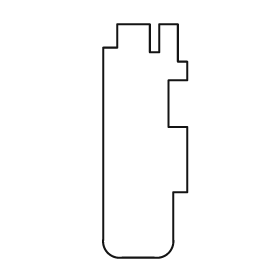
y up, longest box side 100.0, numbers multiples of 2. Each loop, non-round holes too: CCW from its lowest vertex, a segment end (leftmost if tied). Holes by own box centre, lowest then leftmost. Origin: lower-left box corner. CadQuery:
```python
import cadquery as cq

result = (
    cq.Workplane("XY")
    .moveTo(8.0, 0.0)
    .lineTo(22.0, 0.0)
    .threePointArc((28.0, 2.0), (30.0, 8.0))
    .lineTo(30.0, 28.0)
    .lineTo(36.0, 28.0)
    .lineTo(36.0, 56.0)
    .lineTo(28.0, 56.0)
    .lineTo(28.0, 76.0)
    .lineTo(36.0, 76.0)
    .lineTo(36.0, 84.0)
    .lineTo(32.0, 84.0)
    .lineTo(32.0, 100.0)
    .lineTo(24.0, 100.0)
    .lineTo(24.0, 88.0)
    .lineTo(20.0, 88.0)
    .lineTo(20.0, 100.0)
    .lineTo(6.0, 100.0)
    .lineTo(6.0, 90.0)
    .lineTo(0.0, 90.0)
    .lineTo(0.0, 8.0)
    .threePointArc((2.0, 2.0), (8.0, 0.0))
    .close()
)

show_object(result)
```